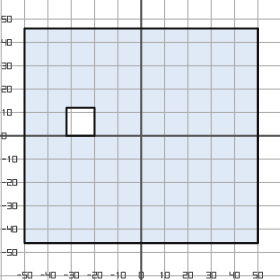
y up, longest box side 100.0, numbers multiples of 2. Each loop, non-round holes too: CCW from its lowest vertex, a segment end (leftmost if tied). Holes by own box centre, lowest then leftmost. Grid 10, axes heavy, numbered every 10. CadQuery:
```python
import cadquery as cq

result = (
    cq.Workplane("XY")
    .moveTo(-50.0, -46.0)
    .lineTo(50.0, -46.0)
    .lineTo(50.0, 46.0)
    .lineTo(-50.0, 46.0)
    .close()
    .moveTo(-32.0, 0.0)
    .lineTo(-20.0, 0.0)
    .lineTo(-20.0, 12.0)
    .lineTo(-32.0, 12.0)
    .close()
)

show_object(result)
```